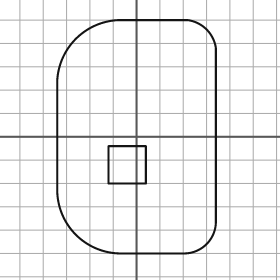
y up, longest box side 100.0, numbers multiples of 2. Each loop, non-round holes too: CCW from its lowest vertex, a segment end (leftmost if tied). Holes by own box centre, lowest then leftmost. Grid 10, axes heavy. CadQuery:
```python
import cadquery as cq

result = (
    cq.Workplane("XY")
    .moveTo(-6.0, -50.0)
    .lineTo(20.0, -50.0)
    .threePointArc((30.0, -46.0), (34.0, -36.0))
    .lineTo(34.0, 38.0)
    .threePointArc((30.0, 46.0), (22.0, 50.0))
    .lineTo(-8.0, 50.0)
    .threePointArc((-26.0, 42.0), (-34.0, 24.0))
    .lineTo(-34.0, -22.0)
    .threePointArc((-26.0, -42.0), (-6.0, -50.0))
    .close()
    .moveTo(-12.0, -20.0)
    .lineTo(4.0, -20.0)
    .lineTo(4.0, -4.0)
    .lineTo(-12.0, -4.0)
    .close()
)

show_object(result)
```